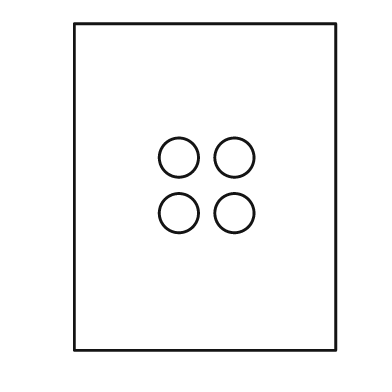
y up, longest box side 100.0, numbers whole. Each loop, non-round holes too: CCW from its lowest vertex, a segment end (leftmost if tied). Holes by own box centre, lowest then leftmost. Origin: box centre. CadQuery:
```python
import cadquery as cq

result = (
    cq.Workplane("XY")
    .moveTo(-40.0, -50.0)
    .lineTo(40.0, -50.0)
    .lineTo(40.0, 50.0)
    .lineTo(-40.0, 50.0)
    .close()
    .moveTo(-8.0, -8.0)
    .circle(6.0)
    .moveTo(9.0, -8.0)
    .circle(6.0)
    .moveTo(-8.0, 9.0)
    .circle(6.0)
    .moveTo(9.0, 9.0)
    .circle(6.0)
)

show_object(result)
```